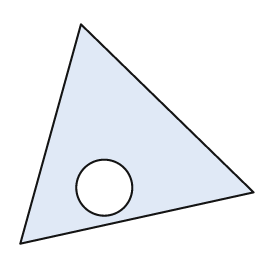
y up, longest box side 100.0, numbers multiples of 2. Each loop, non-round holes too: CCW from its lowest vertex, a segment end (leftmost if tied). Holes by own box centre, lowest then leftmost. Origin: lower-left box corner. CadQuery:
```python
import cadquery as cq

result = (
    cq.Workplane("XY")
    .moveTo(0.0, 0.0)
    .lineTo(100.0, 22.0)
    .lineTo(26.0, 94.0)
    .close()
    .moveTo(36.0, 24.0)
    .circle(12.0)
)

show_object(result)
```